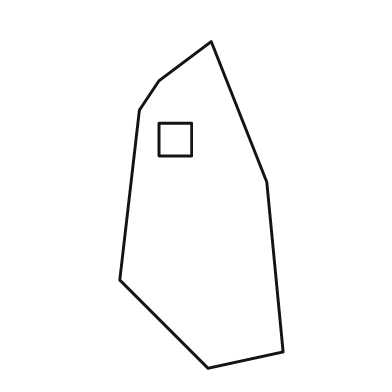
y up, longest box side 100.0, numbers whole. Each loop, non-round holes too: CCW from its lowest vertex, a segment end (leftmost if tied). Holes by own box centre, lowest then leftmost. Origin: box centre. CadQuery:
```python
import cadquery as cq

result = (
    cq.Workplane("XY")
    .moveTo(2.0, -50.0)
    .lineTo(25.0, -45.0)
    .lineTo(20.0, 7.0)
    .lineTo(3.0, 50.0)
    .lineTo(-13.0, 38.0)
    .lineTo(-19.0, 29.0)
    .lineTo(-25.0, -23.0)
    .close()
    .moveTo(-13.0, 15.0)
    .lineTo(-3.0, 15.0)
    .lineTo(-3.0, 25.0)
    .lineTo(-13.0, 25.0)
    .close()
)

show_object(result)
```